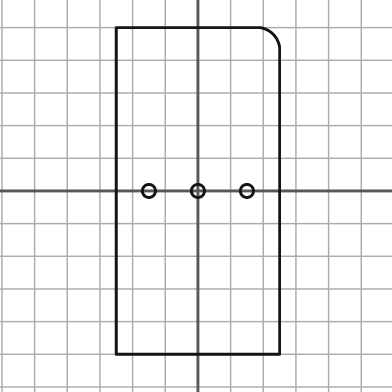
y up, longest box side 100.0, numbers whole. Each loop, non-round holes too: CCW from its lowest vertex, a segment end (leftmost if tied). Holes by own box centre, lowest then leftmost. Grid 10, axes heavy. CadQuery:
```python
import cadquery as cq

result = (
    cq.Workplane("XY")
    .moveTo(-25.0, -50.0)
    .lineTo(25.0, -50.0)
    .lineTo(25.0, 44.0)
    .threePointArc((23.0, 48.0), (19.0, 50.0))
    .lineTo(-25.0, 50.0)
    .close()
    .moveTo(-15.0, 0.0)
    .circle(2.0)
    .moveTo(0.0, 0.0)
    .circle(2.0)
    .moveTo(15.0, 0.0)
    .circle(2.0)
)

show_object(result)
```